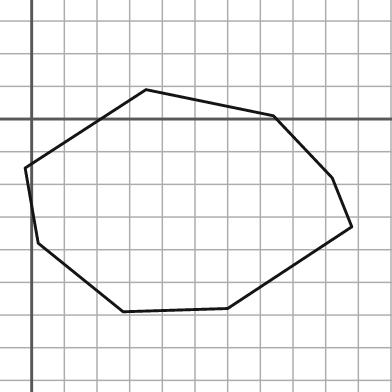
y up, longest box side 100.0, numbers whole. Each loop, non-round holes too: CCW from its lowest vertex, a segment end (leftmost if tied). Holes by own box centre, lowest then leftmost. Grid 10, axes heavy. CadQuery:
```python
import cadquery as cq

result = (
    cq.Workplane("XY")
    .moveTo(28.0, -59.0)
    .lineTo(60.0, -58.0)
    .lineTo(98.0, -33.0)
    .lineTo(92.0, -18.0)
    .lineTo(74.0, 1.0)
    .lineTo(35.0, 9.0)
    .lineTo(-2.0, -15.0)
    .lineTo(2.0, -38.0)
    .close()
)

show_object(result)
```